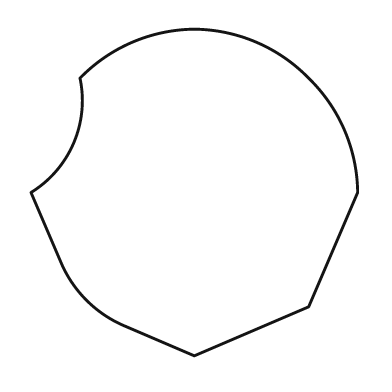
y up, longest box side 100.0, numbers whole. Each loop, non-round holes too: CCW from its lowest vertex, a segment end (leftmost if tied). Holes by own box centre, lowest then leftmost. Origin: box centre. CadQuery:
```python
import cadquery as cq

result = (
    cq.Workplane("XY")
    .moveTo(0.0, -50.0)
    .lineTo(35.0, -35.0)
    .lineTo(50.0, 0.0)
    .threePointArc((46.0, 19.0), (35.0, 35.0))
    .threePointArc((19.0, 46.0), (0.0, 50.0))
    .threePointArc((-19.0, 46.0), (-35.0, 35.0))
    .threePointArc((-37.0, 15.0), (-50.0, 0.0))
    .lineTo(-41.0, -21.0)
    .threePointArc((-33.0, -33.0), (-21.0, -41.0))
    .close()
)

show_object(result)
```